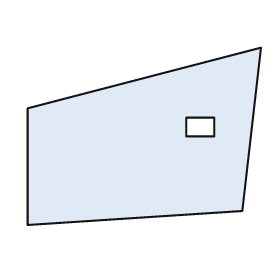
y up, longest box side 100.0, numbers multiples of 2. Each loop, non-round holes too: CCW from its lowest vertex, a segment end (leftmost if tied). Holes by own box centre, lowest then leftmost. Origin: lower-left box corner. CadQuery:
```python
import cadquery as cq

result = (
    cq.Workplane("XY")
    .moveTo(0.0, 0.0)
    .lineTo(92.0, 6.0)
    .lineTo(100.0, 76.0)
    .lineTo(0.0, 50.0)
    .close()
    .moveTo(68.0, 38.0)
    .lineTo(80.0, 38.0)
    .lineTo(80.0, 46.0)
    .lineTo(68.0, 46.0)
    .close()
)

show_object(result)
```